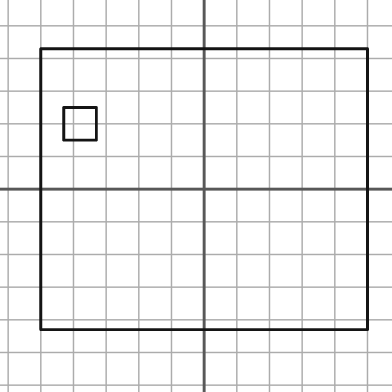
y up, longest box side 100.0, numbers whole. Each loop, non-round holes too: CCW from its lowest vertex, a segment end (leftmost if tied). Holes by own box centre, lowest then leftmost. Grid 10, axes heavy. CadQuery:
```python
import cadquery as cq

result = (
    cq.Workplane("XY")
    .moveTo(-50.0, -43.0)
    .lineTo(50.0, -43.0)
    .lineTo(50.0, 43.0)
    .lineTo(-50.0, 43.0)
    .close()
    .moveTo(-43.0, 15.0)
    .lineTo(-33.0, 15.0)
    .lineTo(-33.0, 25.0)
    .lineTo(-43.0, 25.0)
    .close()
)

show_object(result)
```